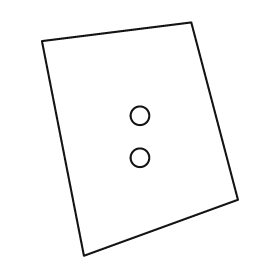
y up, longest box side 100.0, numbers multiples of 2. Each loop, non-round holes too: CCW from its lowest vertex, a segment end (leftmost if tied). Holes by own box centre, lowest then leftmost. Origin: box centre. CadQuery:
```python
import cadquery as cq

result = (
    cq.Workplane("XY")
    .moveTo(-24.0, -50.0)
    .lineTo(42.0, -26.0)
    .lineTo(22.0, 50.0)
    .lineTo(-42.0, 42.0)
    .close()
    .moveTo(0.0, -8.0)
    .circle(4.0)
    .moveTo(0.0, 10.0)
    .circle(4.0)
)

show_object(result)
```